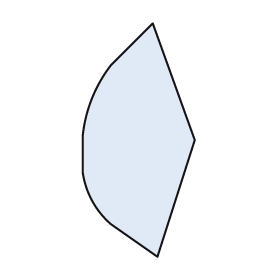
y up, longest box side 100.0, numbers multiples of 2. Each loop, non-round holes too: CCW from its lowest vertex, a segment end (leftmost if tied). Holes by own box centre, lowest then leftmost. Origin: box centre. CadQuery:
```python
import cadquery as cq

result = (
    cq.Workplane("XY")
    .moveTo(8.0, -50.0)
    .lineTo(24.0, 0.0)
    .lineTo(6.0, 50.0)
    .lineTo(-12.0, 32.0)
    .threePointArc((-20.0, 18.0), (-24.0, 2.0))
    .lineTo(-24.0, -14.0)
    .threePointArc((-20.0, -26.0), (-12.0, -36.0))
    .close()
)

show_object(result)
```